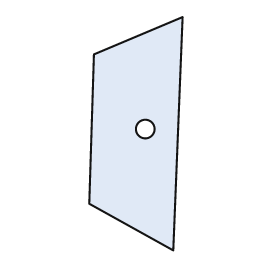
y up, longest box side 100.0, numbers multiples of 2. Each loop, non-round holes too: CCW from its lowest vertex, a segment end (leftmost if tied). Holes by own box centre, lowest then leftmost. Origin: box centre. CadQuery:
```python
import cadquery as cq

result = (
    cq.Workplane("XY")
    .moveTo(16.0, -50.0)
    .lineTo(20.0, 50.0)
    .lineTo(-18.0, 34.0)
    .lineTo(-20.0, -30.0)
    .close()
    .moveTo(4.0, 2.0)
    .circle(4.0)
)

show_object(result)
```